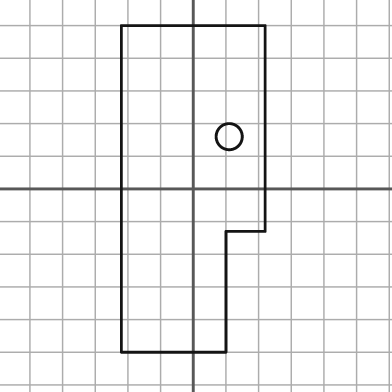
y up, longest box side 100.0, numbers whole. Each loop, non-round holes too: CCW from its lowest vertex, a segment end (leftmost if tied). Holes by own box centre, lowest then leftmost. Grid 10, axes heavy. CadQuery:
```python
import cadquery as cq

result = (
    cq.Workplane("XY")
    .moveTo(-22.0, -50.0)
    .lineTo(10.0, -50.0)
    .lineTo(10.0, -13.0)
    .lineTo(22.0, -13.0)
    .lineTo(22.0, 50.0)
    .lineTo(-22.0, 50.0)
    .close()
    .moveTo(11.0, 16.0)
    .circle(4.0)
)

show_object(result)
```